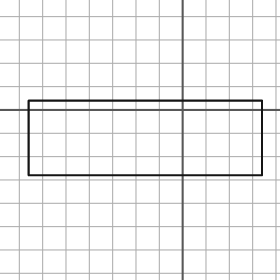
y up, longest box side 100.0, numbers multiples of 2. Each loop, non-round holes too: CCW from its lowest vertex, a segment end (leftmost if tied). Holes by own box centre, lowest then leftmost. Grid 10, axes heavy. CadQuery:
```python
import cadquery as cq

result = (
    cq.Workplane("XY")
    .moveTo(-66.0, -28.0)
    .lineTo(34.0, -28.0)
    .lineTo(34.0, 4.0)
    .lineTo(-66.0, 4.0)
    .close()
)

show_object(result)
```